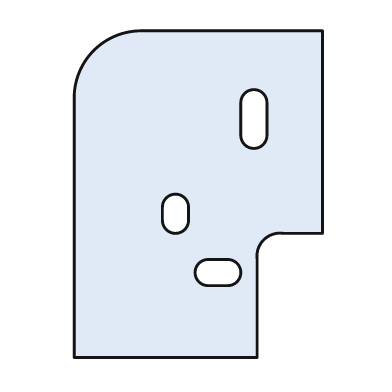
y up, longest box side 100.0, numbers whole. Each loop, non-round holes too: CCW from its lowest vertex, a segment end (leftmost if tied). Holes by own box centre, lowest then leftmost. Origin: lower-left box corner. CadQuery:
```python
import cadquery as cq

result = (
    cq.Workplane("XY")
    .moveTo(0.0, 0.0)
    .lineTo(56.0, 0.0)
    .lineTo(56.0, 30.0)
    .threePointArc((58.0, 36.0), (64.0, 38.0))
    .lineTo(76.0, 38.0)
    .lineTo(76.0, 100.0)
    .lineTo(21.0, 100.0)
    .threePointArc((6.0, 94.0), (0.0, 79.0))
    .close()
    .moveTo(41.0, 22.0)
    .lineTo(47.0, 22.0)
    .threePointArc((51.0, 26.0), (47.0, 30.0))
    .lineTo(41.0, 30.0)
    .threePointArc((37.0, 26.0), (41.0, 22.0))
    .close()
    .moveTo(27.0, 42.0)
    .threePointArc((31.0, 38.0), (35.0, 42.0))
    .lineTo(35.0, 46.0)
    .threePointArc((31.0, 50.0), (27.0, 46.0))
    .close()
    .moveTo(51.0, 68.0)
    .threePointArc((55.0, 64.0), (59.0, 68.0))
    .lineTo(59.0, 78.0)
    .threePointArc((55.0, 82.0), (51.0, 78.0))
    .close()
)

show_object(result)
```